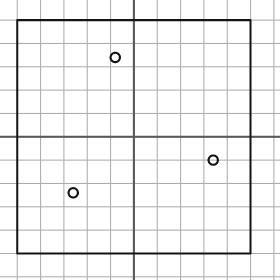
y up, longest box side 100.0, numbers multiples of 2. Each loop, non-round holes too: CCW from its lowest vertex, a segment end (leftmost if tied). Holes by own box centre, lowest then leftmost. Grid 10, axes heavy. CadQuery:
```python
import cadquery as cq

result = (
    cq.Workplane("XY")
    .moveTo(-50.0, -50.0)
    .lineTo(50.0, -50.0)
    .lineTo(50.0, 50.0)
    .lineTo(-50.0, 50.0)
    .close()
    .moveTo(-26.0, -24.0)
    .circle(2.0)
    .moveTo(34.0, -10.0)
    .circle(2.0)
    .moveTo(-8.0, 34.0)
    .circle(2.0)
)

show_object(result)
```